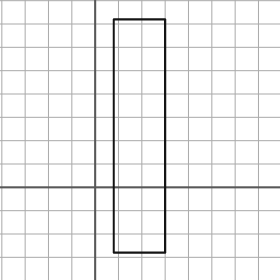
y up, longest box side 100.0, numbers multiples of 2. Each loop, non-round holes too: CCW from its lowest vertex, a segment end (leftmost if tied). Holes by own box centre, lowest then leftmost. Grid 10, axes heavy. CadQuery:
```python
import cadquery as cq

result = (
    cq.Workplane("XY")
    .moveTo(8.0, -28.0)
    .lineTo(30.0, -28.0)
    .lineTo(30.0, 72.0)
    .lineTo(8.0, 72.0)
    .close()
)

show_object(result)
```